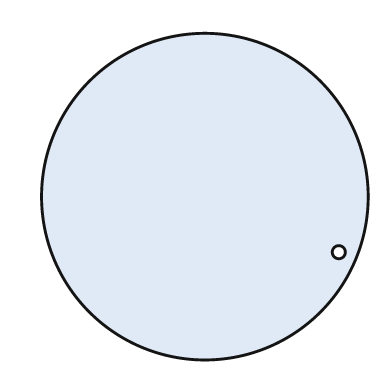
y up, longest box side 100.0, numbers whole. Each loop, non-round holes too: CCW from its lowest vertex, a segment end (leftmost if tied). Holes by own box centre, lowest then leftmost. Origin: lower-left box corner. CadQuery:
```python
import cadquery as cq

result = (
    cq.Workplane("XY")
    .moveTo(50.0, 50.0)
    .circle(50.0)
    .moveTo(91.0, 33.0)
    .circle(2.0)
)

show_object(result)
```